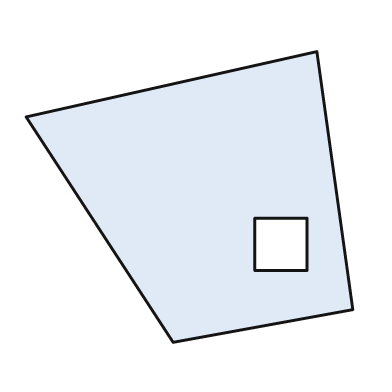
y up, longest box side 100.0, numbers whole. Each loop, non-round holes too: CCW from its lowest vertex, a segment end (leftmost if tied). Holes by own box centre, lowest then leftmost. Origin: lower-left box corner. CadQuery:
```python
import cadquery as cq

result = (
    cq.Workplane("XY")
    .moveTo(45.0, 0.0)
    .lineTo(100.0, 10.0)
    .lineTo(89.0, 89.0)
    .lineTo(0.0, 69.0)
    .close()
    .moveTo(70.0, 22.0)
    .lineTo(86.0, 22.0)
    .lineTo(86.0, 38.0)
    .lineTo(70.0, 38.0)
    .close()
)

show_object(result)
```